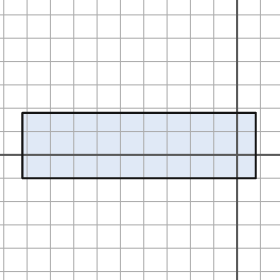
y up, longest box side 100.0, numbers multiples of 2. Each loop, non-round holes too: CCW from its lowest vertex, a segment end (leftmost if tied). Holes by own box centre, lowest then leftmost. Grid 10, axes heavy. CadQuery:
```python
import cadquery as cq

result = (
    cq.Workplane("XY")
    .moveTo(-92.0, -10.0)
    .lineTo(8.0, -10.0)
    .lineTo(8.0, 18.0)
    .lineTo(-92.0, 18.0)
    .close()
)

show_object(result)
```